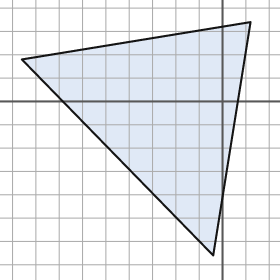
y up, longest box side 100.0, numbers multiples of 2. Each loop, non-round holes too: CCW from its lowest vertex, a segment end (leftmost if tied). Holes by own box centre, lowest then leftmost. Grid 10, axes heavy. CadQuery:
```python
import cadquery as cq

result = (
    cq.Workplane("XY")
    .moveTo(-4.0, -66.0)
    .lineTo(12.0, 34.0)
    .lineTo(-86.0, 18.0)
    .close()
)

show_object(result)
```